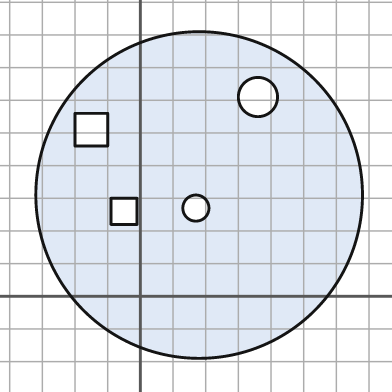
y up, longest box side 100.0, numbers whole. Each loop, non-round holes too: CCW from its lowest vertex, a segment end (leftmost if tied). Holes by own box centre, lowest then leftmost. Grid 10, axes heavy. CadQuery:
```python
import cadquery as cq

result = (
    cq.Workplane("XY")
    .moveTo(18.0, 31.0)
    .circle(50.0)
    .moveTo(-9.0, 22.0)
    .lineTo(-1.0, 22.0)
    .lineTo(-1.0, 30.0)
    .lineTo(-9.0, 30.0)
    .close()
    .moveTo(17.0, 27.0)
    .circle(4.0)
    .moveTo(-20.0, 46.0)
    .lineTo(-10.0, 46.0)
    .lineTo(-10.0, 56.0)
    .lineTo(-20.0, 56.0)
    .close()
    .moveTo(36.0, 61.0)
    .circle(6.0)
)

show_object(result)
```